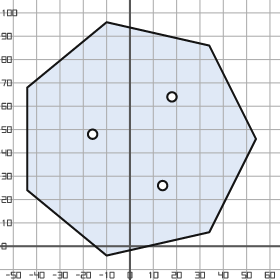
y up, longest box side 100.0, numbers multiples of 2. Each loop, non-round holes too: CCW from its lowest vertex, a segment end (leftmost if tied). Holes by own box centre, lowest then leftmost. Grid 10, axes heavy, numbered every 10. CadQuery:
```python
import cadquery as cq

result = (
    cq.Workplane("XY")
    .moveTo(-10.0, -4.0)
    .lineTo(34.0, 6.0)
    .lineTo(54.0, 46.0)
    .lineTo(34.0, 86.0)
    .lineTo(-10.0, 96.0)
    .lineTo(-44.0, 68.0)
    .lineTo(-44.0, 24.0)
    .close()
    .moveTo(14.0, 26.0)
    .circle(2.0)
    .moveTo(-16.0, 48.0)
    .circle(2.0)
    .moveTo(18.0, 64.0)
    .circle(2.0)
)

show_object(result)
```